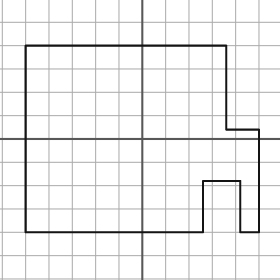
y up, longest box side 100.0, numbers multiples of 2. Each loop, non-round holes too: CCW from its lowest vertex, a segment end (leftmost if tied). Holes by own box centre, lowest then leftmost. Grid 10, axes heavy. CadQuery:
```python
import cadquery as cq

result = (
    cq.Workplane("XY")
    .moveTo(-50.0, -40.0)
    .lineTo(26.0, -40.0)
    .lineTo(26.0, -18.0)
    .lineTo(42.0, -18.0)
    .lineTo(42.0, -40.0)
    .lineTo(50.0, -40.0)
    .lineTo(50.0, 4.0)
    .lineTo(36.0, 4.0)
    .lineTo(36.0, 40.0)
    .lineTo(-50.0, 40.0)
    .close()
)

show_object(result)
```